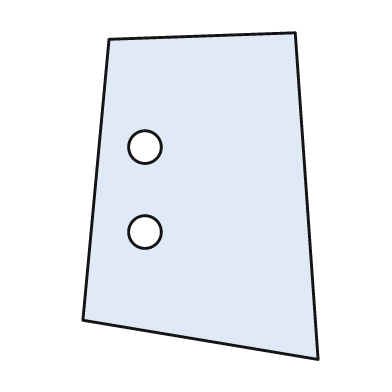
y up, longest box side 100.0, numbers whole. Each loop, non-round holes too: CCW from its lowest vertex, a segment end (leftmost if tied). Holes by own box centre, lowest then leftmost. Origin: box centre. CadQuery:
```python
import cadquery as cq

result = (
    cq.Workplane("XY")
    .moveTo(36.0, -50.0)
    .lineTo(29.0, 50.0)
    .lineTo(-28.0, 48.0)
    .lineTo(-36.0, -38.0)
    .close()
    .moveTo(-17.0, -11.0)
    .circle(5.0)
    .moveTo(-17.0, 15.0)
    .circle(5.0)
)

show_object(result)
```